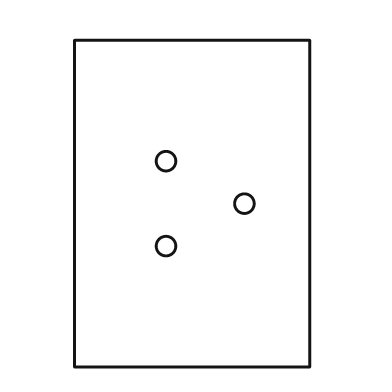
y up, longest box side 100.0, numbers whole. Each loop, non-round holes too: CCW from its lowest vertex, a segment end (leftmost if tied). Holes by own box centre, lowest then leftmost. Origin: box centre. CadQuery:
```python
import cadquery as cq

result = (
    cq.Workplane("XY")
    .moveTo(-36.0, -50.0)
    .lineTo(36.0, -50.0)
    .lineTo(36.0, 50.0)
    .lineTo(-36.0, 50.0)
    .close()
    .moveTo(-8.0, -13.0)
    .circle(3.0)
    .moveTo(16.0, 0.0)
    .circle(3.0)
    .moveTo(-8.0, 13.0)
    .circle(3.0)
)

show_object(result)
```